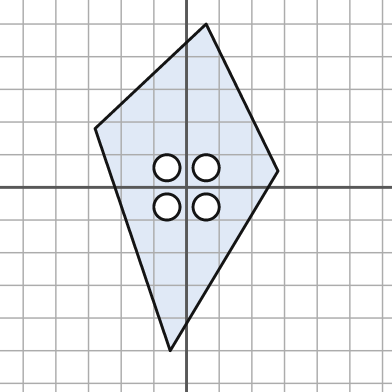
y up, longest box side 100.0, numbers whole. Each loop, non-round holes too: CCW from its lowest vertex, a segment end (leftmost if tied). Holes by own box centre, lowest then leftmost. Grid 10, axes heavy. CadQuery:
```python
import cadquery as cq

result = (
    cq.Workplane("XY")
    .moveTo(-5.0, -50.0)
    .lineTo(28.0, 5.0)
    .lineTo(6.0, 50.0)
    .lineTo(-28.0, 18.0)
    .close()
    .moveTo(-6.0, -6.0)
    .circle(4.0)
    .moveTo(6.0, -6.0)
    .circle(4.0)
    .moveTo(-6.0, 6.0)
    .circle(4.0)
    .moveTo(6.0, 6.0)
    .circle(4.0)
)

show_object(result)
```